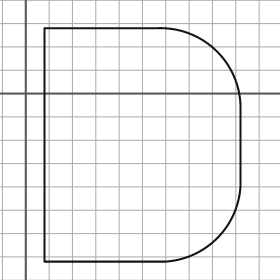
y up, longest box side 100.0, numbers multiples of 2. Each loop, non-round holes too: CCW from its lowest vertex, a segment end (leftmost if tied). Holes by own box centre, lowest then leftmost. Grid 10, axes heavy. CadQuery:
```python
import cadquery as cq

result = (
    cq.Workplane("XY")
    .moveTo(8.0, -72.0)
    .lineTo(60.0, -72.0)
    .threePointArc((82.0, -62.0), (92.0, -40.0))
    .lineTo(92.0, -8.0)
    .threePointArc((82.0, 18.0), (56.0, 28.0))
    .lineTo(8.0, 28.0)
    .close()
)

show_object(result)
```